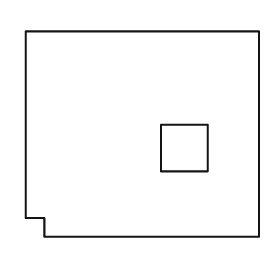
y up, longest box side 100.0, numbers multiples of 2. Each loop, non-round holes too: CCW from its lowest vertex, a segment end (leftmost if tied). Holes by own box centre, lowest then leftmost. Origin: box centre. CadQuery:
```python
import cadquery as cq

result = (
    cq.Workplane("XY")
    .moveTo(-42.0, -44.0)
    .lineTo(50.0, -44.0)
    .lineTo(50.0, 44.0)
    .lineTo(-50.0, 44.0)
    .lineTo(-50.0, -36.0)
    .lineTo(-42.0, -36.0)
    .close()
    .moveTo(8.0, -16.0)
    .lineTo(28.0, -16.0)
    .lineTo(28.0, 4.0)
    .lineTo(8.0, 4.0)
    .close()
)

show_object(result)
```